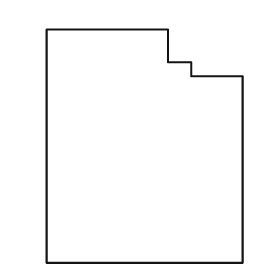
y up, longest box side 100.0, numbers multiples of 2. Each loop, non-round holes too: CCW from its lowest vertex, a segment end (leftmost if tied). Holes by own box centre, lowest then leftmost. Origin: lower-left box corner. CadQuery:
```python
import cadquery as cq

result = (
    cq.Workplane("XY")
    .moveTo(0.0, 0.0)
    .lineTo(84.0, 0.0)
    .lineTo(84.0, 80.0)
    .lineTo(62.0, 80.0)
    .lineTo(62.0, 86.0)
    .lineTo(52.0, 86.0)
    .lineTo(52.0, 100.0)
    .lineTo(0.0, 100.0)
    .close()
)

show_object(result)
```